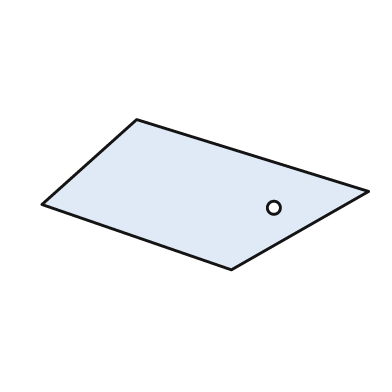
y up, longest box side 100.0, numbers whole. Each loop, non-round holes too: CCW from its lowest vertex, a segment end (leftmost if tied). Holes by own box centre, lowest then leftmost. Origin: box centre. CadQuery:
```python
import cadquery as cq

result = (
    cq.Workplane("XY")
    .moveTo(8.0, -23.0)
    .lineTo(50.0, 1.0)
    .lineTo(-21.0, 23.0)
    .lineTo(-50.0, -3.0)
    .close()
    .moveTo(21.0, -4.0)
    .circle(2.0)
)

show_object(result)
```